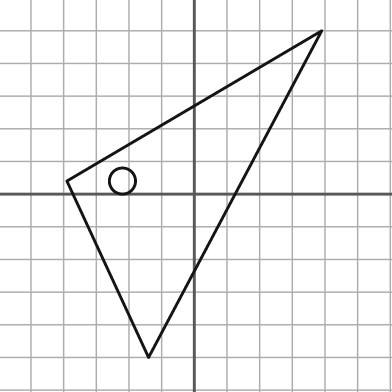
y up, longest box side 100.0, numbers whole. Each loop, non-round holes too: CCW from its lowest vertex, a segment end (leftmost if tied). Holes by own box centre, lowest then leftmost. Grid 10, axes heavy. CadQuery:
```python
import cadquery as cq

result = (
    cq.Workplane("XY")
    .moveTo(-14.0, -50.0)
    .lineTo(39.0, 50.0)
    .lineTo(-39.0, 4.0)
    .close()
    .moveTo(-22.0, 4.0)
    .circle(4.0)
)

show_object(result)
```